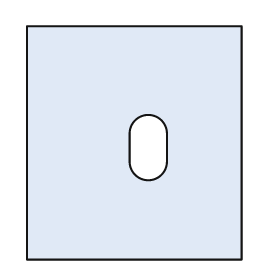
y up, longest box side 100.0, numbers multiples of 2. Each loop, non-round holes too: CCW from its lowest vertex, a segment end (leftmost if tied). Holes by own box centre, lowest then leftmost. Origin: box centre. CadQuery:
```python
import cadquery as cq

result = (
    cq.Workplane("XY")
    .moveTo(-46.0, -50.0)
    .lineTo(46.0, -50.0)
    .lineTo(46.0, 50.0)
    .lineTo(-46.0, 50.0)
    .close()
    .moveTo(-2.0, -8.0)
    .threePointArc((6.0, -16.0), (14.0, -8.0))
    .lineTo(14.0, 4.0)
    .threePointArc((6.0, 12.0), (-2.0, 4.0))
    .close()
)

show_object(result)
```